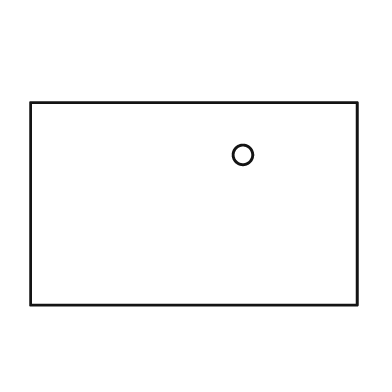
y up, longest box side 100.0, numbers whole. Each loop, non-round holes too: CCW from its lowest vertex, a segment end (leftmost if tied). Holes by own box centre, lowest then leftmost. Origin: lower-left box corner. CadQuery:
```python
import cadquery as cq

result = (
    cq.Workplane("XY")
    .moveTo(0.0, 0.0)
    .lineTo(100.0, 0.0)
    .lineTo(100.0, 62.0)
    .lineTo(0.0, 62.0)
    .close()
    .moveTo(65.0, 46.0)
    .circle(3.0)
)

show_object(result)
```